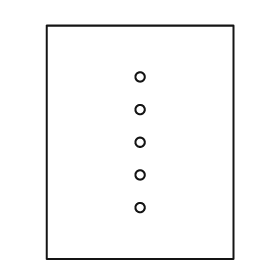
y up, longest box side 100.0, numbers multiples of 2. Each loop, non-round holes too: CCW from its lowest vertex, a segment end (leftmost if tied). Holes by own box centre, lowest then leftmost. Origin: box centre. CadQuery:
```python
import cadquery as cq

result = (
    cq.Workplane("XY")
    .moveTo(-40.0, -50.0)
    .lineTo(40.0, -50.0)
    .lineTo(40.0, 50.0)
    .lineTo(-40.0, 50.0)
    .close()
    .moveTo(0.0, -28.0)
    .circle(2.0)
    .moveTo(0.0, -14.0)
    .circle(2.0)
    .moveTo(0.0, 0.0)
    .circle(2.0)
    .moveTo(0.0, 14.0)
    .circle(2.0)
    .moveTo(0.0, 28.0)
    .circle(2.0)
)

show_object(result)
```